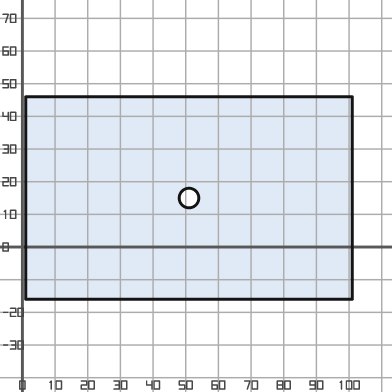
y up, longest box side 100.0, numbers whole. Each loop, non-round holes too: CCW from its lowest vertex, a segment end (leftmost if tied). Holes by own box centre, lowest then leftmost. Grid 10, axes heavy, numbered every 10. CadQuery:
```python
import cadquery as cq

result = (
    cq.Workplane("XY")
    .moveTo(1.0, -16.0)
    .lineTo(101.0, -16.0)
    .lineTo(101.0, 46.0)
    .lineTo(1.0, 46.0)
    .close()
    .moveTo(51.0, 15.0)
    .circle(3.0)
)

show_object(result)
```